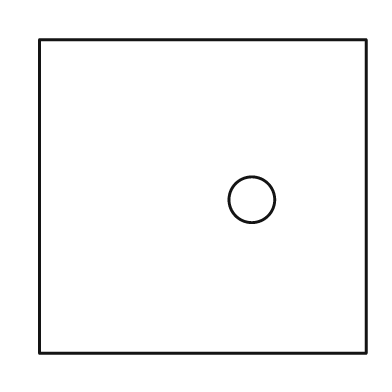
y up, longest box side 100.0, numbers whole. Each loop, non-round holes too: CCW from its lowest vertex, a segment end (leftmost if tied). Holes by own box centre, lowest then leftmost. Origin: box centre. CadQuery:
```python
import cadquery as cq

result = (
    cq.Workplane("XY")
    .moveTo(-50.0, -48.0)
    .lineTo(50.0, -48.0)
    .lineTo(50.0, 48.0)
    .lineTo(-50.0, 48.0)
    .close()
    .moveTo(15.0, -1.0)
    .circle(7.0)
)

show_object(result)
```